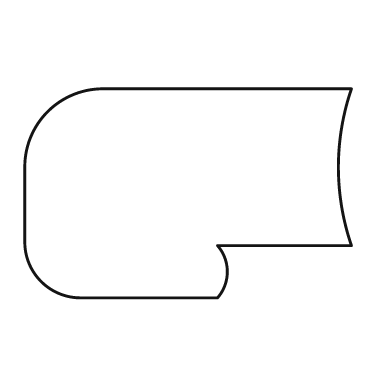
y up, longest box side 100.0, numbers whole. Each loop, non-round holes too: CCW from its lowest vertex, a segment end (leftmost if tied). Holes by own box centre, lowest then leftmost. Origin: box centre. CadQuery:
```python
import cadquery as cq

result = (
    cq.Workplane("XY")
    .moveTo(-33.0, -32.0)
    .lineTo(9.0, -32.0)
    .threePointArc((12.0, -24.0), (9.0, -16.0))
    .lineTo(50.0, -16.0)
    .threePointArc((46.0, 8.0), (50.0, 32.0))
    .lineTo(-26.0, 32.0)
    .threePointArc((-43.0, 25.0), (-50.0, 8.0))
    .lineTo(-50.0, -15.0)
    .threePointArc((-45.0, -27.0), (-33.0, -32.0))
    .close()
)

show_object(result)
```